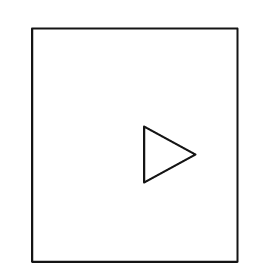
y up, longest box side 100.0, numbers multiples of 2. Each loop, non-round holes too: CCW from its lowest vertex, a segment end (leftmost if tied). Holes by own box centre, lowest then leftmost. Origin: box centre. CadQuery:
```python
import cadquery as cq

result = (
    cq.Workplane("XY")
    .moveTo(-44.0, -50.0)
    .lineTo(44.0, -50.0)
    .lineTo(44.0, 50.0)
    .lineTo(-44.0, 50.0)
    .close()
    .moveTo(4.0, -16.0)
    .lineTo(26.0, -4.0)
    .lineTo(4.0, 8.0)
    .close()
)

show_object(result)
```